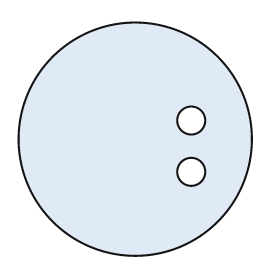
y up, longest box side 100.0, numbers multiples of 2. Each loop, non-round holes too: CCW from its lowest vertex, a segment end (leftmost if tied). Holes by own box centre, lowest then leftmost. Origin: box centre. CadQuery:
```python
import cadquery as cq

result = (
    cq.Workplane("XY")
    .moveTo(0.0, 0.0)
    .circle(50.0)
    .moveTo(24.0, -14.0)
    .circle(6.0)
    .moveTo(24.0, 8.0)
    .circle(6.0)
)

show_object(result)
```